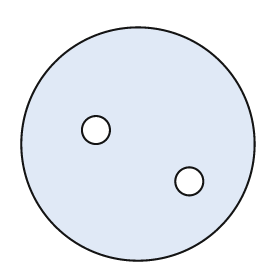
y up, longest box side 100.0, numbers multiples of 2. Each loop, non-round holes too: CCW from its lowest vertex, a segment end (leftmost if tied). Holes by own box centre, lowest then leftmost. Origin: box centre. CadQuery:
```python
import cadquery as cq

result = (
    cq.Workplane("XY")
    .moveTo(0.0, 0.0)
    .circle(50.0)
    .moveTo(22.0, -16.0)
    .circle(6.0)
    .moveTo(-18.0, 6.0)
    .circle(6.0)
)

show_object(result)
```